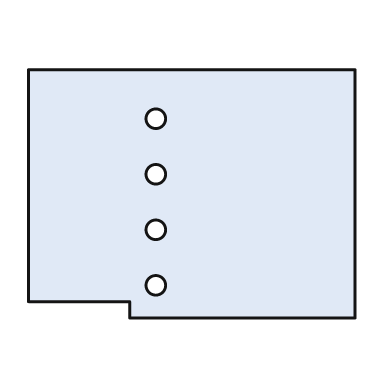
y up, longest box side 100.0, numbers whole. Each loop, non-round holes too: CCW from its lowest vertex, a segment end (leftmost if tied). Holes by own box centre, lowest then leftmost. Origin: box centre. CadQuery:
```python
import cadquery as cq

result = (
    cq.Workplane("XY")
    .moveTo(-19.0, -38.0)
    .lineTo(50.0, -38.0)
    .lineTo(50.0, 38.0)
    .lineTo(-50.0, 38.0)
    .lineTo(-50.0, -33.0)
    .lineTo(-19.0, -33.0)
    .close()
    .moveTo(-11.0, -28.0)
    .circle(3.0)
    .moveTo(-11.0, -11.0)
    .circle(3.0)
    .moveTo(-11.0, 6.0)
    .circle(3.0)
    .moveTo(-11.0, 23.0)
    .circle(3.0)
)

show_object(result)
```